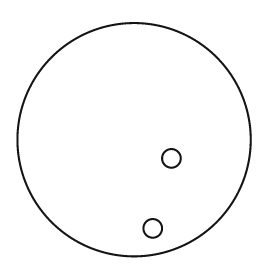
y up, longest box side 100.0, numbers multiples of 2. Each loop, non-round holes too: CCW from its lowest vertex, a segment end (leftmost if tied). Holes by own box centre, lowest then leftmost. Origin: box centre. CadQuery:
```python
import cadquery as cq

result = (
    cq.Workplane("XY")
    .moveTo(0.0, 0.0)
    .circle(50.0)
    .moveTo(8.0, -38.0)
    .circle(4.0)
    .moveTo(16.0, -8.0)
    .circle(4.0)
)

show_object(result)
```